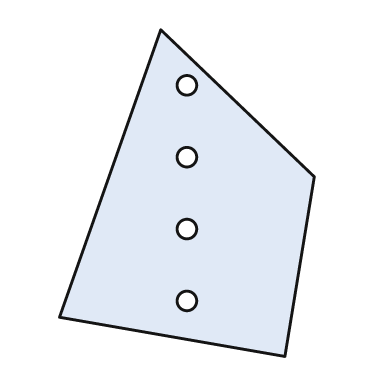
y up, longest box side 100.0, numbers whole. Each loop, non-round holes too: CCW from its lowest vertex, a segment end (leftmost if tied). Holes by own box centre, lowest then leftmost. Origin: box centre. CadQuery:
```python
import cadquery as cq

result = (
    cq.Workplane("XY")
    .moveTo(30.0, -50.0)
    .lineTo(39.0, 5.0)
    .lineTo(-8.0, 50.0)
    .lineTo(-39.0, -38.0)
    .close()
    .moveTo(0.0, -33.0)
    .circle(3.0)
    .moveTo(0.0, -11.0)
    .circle(3.0)
    .moveTo(0.0, 11.0)
    .circle(3.0)
    .moveTo(0.0, 33.0)
    .circle(3.0)
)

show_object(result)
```